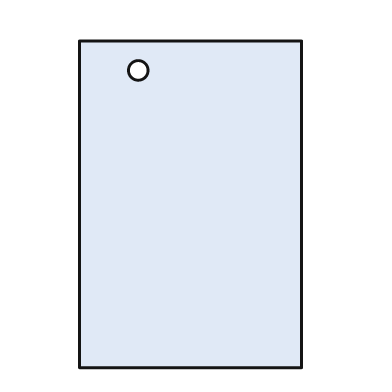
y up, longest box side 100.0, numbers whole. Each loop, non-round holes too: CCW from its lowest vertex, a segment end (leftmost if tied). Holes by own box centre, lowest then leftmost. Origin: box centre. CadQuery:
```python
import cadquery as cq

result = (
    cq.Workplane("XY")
    .moveTo(-34.0, -50.0)
    .lineTo(34.0, -50.0)
    .lineTo(34.0, 50.0)
    .lineTo(-34.0, 50.0)
    .close()
    .moveTo(-16.0, 41.0)
    .circle(3.0)
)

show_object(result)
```